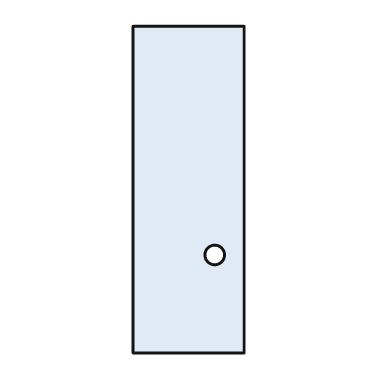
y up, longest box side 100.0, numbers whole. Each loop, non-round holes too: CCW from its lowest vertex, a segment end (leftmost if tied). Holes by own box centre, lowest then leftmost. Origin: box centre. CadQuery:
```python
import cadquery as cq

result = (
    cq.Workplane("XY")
    .moveTo(-17.0, -50.0)
    .lineTo(17.0, -50.0)
    .lineTo(17.0, 50.0)
    .lineTo(-17.0, 50.0)
    .close()
    .moveTo(8.0, -20.0)
    .circle(3.0)
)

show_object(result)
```